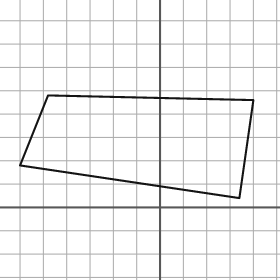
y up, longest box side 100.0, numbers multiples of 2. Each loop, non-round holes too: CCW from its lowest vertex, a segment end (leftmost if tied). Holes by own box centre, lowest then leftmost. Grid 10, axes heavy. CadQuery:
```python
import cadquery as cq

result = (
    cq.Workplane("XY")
    .moveTo(34.0, 4.0)
    .lineTo(40.0, 46.0)
    .lineTo(-48.0, 48.0)
    .lineTo(-60.0, 18.0)
    .close()
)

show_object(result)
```